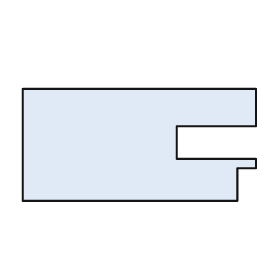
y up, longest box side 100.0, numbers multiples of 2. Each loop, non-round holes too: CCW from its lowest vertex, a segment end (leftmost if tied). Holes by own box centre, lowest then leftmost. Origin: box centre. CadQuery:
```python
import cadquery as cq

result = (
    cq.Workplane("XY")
    .moveTo(-50.0, -24.0)
    .lineTo(42.0, -24.0)
    .lineTo(42.0, -10.0)
    .lineTo(50.0, -10.0)
    .lineTo(50.0, -6.0)
    .lineTo(16.0, -6.0)
    .lineTo(16.0, 8.0)
    .lineTo(50.0, 8.0)
    .lineTo(50.0, 24.0)
    .lineTo(-50.0, 24.0)
    .close()
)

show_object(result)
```